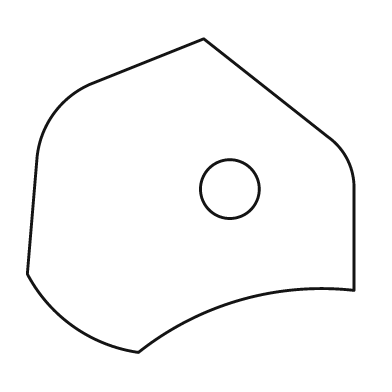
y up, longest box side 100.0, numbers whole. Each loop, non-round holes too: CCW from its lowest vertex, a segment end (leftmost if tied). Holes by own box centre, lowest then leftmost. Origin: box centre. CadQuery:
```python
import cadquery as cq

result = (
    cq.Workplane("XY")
    .moveTo(-16.0, -48.0)
    .threePointArc((15.0, -32.0), (50.0, -29.0))
    .lineTo(50.0, 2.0)
    .threePointArc((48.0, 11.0), (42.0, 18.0))
    .lineTo(4.0, 48.0)
    .lineTo(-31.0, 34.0)
    .threePointArc((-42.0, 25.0), (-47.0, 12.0))
    .lineTo(-50.0, -24.0)
    .threePointArc((-36.0, -40.0), (-16.0, -48.0))
    .close()
    .moveTo(12.0, 2.0)
    .circle(9.0)
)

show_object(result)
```